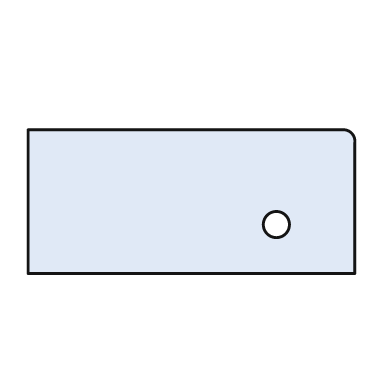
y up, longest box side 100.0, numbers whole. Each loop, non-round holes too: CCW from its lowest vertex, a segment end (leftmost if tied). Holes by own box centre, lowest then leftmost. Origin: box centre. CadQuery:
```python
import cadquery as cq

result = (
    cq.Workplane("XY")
    .moveTo(-50.0, -22.0)
    .lineTo(50.0, -22.0)
    .lineTo(50.0, 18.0)
    .threePointArc((49.0, 21.0), (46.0, 22.0))
    .lineTo(-50.0, 22.0)
    .close()
    .moveTo(26.0, -7.0)
    .circle(4.0)
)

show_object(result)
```